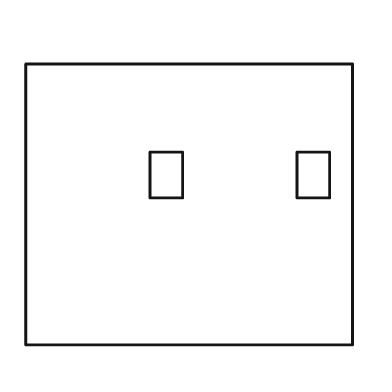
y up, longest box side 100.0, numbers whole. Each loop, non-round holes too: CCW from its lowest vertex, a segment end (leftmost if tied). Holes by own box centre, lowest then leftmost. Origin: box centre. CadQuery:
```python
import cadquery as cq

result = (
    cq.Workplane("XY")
    .moveTo(-50.0, -43.0)
    .lineTo(50.0, -43.0)
    .lineTo(50.0, 43.0)
    .lineTo(-50.0, 43.0)
    .close()
    .moveTo(-12.0, 2.0)
    .lineTo(-2.0, 2.0)
    .lineTo(-2.0, 16.0)
    .lineTo(-12.0, 16.0)
    .close()
    .moveTo(33.0, 2.0)
    .lineTo(43.0, 2.0)
    .lineTo(43.0, 16.0)
    .lineTo(33.0, 16.0)
    .close()
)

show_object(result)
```